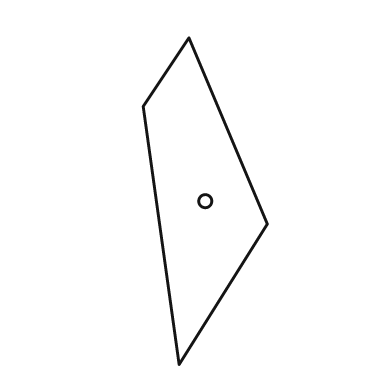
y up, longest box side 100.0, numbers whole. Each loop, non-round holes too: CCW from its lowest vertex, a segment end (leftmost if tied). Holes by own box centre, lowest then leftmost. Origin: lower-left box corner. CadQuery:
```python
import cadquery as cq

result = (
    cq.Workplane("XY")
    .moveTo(11.0, 0.0)
    .lineTo(38.0, 43.0)
    .lineTo(14.0, 100.0)
    .lineTo(0.0, 79.0)
    .close()
    .moveTo(19.0, 50.0)
    .circle(2.0)
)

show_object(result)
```